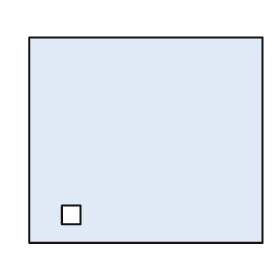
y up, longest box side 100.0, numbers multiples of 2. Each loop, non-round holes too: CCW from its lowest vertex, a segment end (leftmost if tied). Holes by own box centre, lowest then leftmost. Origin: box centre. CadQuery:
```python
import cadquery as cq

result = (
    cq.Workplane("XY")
    .moveTo(-50.0, -44.0)
    .lineTo(50.0, -44.0)
    .lineTo(50.0, 44.0)
    .lineTo(-50.0, 44.0)
    .close()
    .moveTo(-36.0, -36.0)
    .lineTo(-28.0, -36.0)
    .lineTo(-28.0, -28.0)
    .lineTo(-36.0, -28.0)
    .close()
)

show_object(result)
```